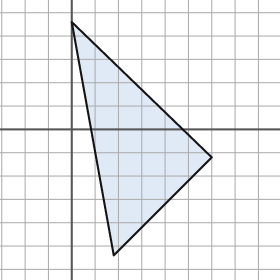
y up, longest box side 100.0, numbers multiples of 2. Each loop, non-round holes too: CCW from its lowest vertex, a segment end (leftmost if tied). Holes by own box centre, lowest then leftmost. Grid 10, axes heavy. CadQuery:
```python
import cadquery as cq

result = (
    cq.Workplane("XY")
    .moveTo(18.0, -54.0)
    .lineTo(60.0, -12.0)
    .lineTo(0.0, 46.0)
    .close()
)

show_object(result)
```